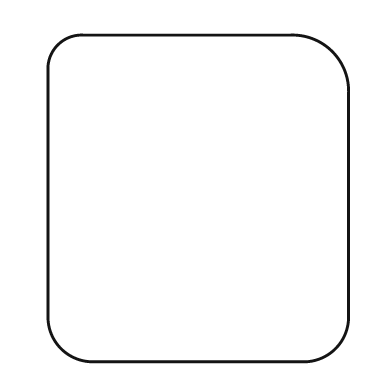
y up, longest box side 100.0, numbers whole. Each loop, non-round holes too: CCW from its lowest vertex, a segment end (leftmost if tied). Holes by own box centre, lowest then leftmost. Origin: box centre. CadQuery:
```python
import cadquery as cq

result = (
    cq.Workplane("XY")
    .moveTo(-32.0, -50.0)
    .lineTo(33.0, -50.0)
    .threePointArc((42.0, -46.0), (46.0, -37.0))
    .lineTo(46.0, 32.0)
    .threePointArc((41.0, 45.0), (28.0, 50.0))
    .lineTo(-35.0, 50.0)
    .threePointArc((-43.0, 47.0), (-46.0, 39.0))
    .lineTo(-46.0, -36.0)
    .threePointArc((-42.0, -46.0), (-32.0, -50.0))
    .close()
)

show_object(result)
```